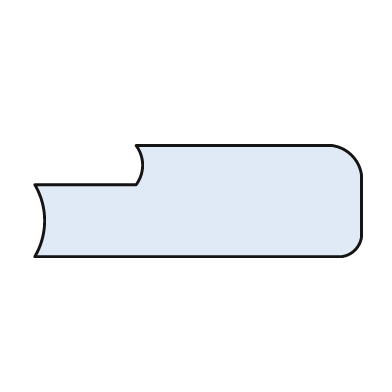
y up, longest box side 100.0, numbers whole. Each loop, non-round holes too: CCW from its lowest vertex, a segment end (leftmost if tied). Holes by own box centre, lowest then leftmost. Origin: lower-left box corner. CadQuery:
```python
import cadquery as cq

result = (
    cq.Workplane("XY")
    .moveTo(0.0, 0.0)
    .lineTo(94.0, 0.0)
    .threePointArc((98.0, 2.0), (100.0, 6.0))
    .lineTo(100.0, 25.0)
    .threePointArc((97.0, 31.0), (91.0, 34.0))
    .lineTo(31.0, 34.0)
    .threePointArc((33.0, 28.0), (31.0, 22.0))
    .lineTo(0.0, 22.0)
    .threePointArc((3.0, 11.0), (0.0, 0.0))
    .close()
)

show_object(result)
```